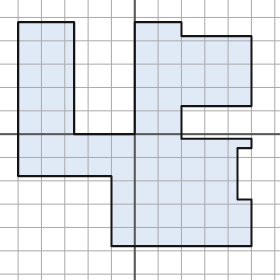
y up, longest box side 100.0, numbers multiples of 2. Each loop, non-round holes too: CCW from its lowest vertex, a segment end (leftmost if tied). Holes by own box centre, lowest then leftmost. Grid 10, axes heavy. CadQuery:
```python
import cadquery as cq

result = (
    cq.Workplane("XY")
    .moveTo(-10.0, -48.0)
    .lineTo(50.0, -48.0)
    .lineTo(50.0, -28.0)
    .lineTo(44.0, -28.0)
    .lineTo(44.0, -6.0)
    .lineTo(50.0, -6.0)
    .lineTo(50.0, -2.0)
    .lineTo(20.0, -2.0)
    .lineTo(20.0, 12.0)
    .lineTo(50.0, 12.0)
    .lineTo(50.0, 42.0)
    .lineTo(20.0, 42.0)
    .lineTo(20.0, 48.0)
    .lineTo(0.0, 48.0)
    .lineTo(0.0, 0.0)
    .lineTo(-26.0, 0.0)
    .lineTo(-26.0, 48.0)
    .lineTo(-50.0, 48.0)
    .lineTo(-50.0, -18.0)
    .lineTo(-10.0, -18.0)
    .close()
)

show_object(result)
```